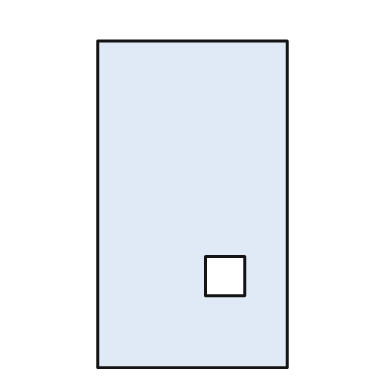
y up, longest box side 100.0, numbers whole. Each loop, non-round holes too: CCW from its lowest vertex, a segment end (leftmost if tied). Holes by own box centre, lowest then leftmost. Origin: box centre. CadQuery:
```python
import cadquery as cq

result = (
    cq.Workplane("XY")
    .moveTo(-29.0, -50.0)
    .lineTo(29.0, -50.0)
    .lineTo(29.0, 50.0)
    .lineTo(-29.0, 50.0)
    .close()
    .moveTo(4.0, -28.0)
    .lineTo(16.0, -28.0)
    .lineTo(16.0, -16.0)
    .lineTo(4.0, -16.0)
    .close()
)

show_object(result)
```